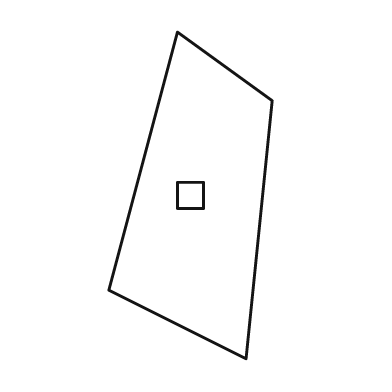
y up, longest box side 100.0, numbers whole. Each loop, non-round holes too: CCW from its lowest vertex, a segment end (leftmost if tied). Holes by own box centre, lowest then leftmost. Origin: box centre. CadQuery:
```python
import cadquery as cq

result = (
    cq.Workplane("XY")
    .moveTo(17.0, -50.0)
    .lineTo(25.0, 29.0)
    .lineTo(-4.0, 50.0)
    .lineTo(-25.0, -29.0)
    .close()
    .moveTo(-4.0, -4.0)
    .lineTo(4.0, -4.0)
    .lineTo(4.0, 4.0)
    .lineTo(-4.0, 4.0)
    .close()
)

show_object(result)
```